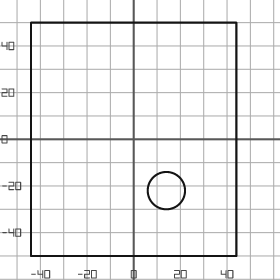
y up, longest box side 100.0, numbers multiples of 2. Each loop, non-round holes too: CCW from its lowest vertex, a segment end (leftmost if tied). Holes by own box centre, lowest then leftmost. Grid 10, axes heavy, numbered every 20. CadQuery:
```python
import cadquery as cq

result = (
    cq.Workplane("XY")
    .moveTo(-44.0, -50.0)
    .lineTo(44.0, -50.0)
    .lineTo(44.0, 50.0)
    .lineTo(-44.0, 50.0)
    .close()
    .moveTo(14.0, -22.0)
    .circle(8.0)
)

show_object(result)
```